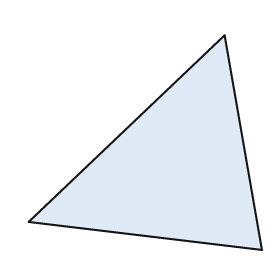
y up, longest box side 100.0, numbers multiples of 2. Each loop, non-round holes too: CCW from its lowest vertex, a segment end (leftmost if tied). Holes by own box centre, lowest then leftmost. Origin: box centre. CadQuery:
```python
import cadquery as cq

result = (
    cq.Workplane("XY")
    .moveTo(50.0, -46.0)
    .lineTo(34.0, 46.0)
    .lineTo(-50.0, -34.0)
    .close()
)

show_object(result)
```